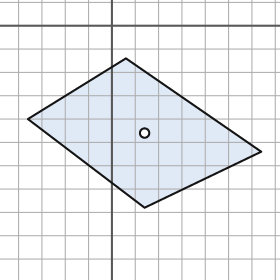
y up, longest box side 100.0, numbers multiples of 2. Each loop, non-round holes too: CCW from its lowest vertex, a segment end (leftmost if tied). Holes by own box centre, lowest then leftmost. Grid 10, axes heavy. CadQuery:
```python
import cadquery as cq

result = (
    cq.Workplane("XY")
    .moveTo(14.0, -78.0)
    .lineTo(64.0, -54.0)
    .lineTo(6.0, -14.0)
    .lineTo(-36.0, -40.0)
    .close()
    .moveTo(14.0, -46.0)
    .circle(2.0)
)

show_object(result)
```